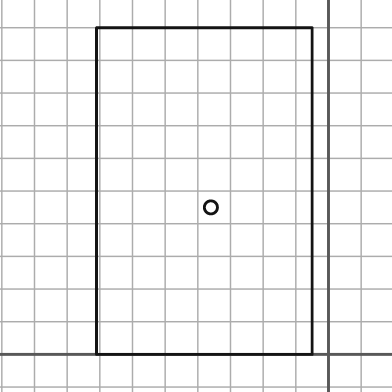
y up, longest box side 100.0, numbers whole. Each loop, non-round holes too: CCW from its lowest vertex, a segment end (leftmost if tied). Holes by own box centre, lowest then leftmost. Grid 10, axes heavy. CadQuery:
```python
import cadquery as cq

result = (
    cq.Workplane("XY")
    .moveTo(-71.0, 0.0)
    .lineTo(-5.0, 0.0)
    .lineTo(-5.0, 100.0)
    .lineTo(-71.0, 100.0)
    .close()
    .moveTo(-36.0, 45.0)
    .circle(2.0)
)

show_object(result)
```